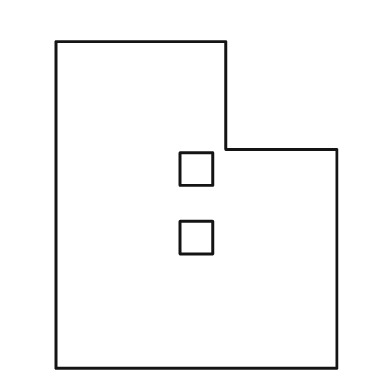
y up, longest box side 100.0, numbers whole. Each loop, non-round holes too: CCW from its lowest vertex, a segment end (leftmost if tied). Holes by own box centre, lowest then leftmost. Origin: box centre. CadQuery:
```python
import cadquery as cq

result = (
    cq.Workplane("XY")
    .moveTo(-43.0, -50.0)
    .lineTo(43.0, -50.0)
    .lineTo(43.0, 17.0)
    .lineTo(9.0, 17.0)
    .lineTo(9.0, 50.0)
    .lineTo(-43.0, 50.0)
    .close()
    .moveTo(-5.0, -15.0)
    .lineTo(5.0, -15.0)
    .lineTo(5.0, -5.0)
    .lineTo(-5.0, -5.0)
    .close()
    .moveTo(-5.0, 6.0)
    .lineTo(5.0, 6.0)
    .lineTo(5.0, 16.0)
    .lineTo(-5.0, 16.0)
    .close()
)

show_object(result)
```